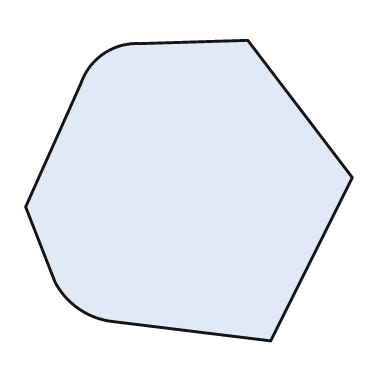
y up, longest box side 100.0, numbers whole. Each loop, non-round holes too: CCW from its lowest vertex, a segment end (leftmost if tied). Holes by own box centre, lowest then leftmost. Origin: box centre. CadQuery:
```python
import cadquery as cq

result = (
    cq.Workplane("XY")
    .moveTo(25.0, -46.0)
    .lineTo(50.0, 4.0)
    .lineTo(18.0, 46.0)
    .lineTo(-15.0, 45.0)
    .threePointArc((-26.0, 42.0), (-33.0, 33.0))
    .lineTo(-50.0, -5.0)
    .lineTo(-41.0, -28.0)
    .threePointArc((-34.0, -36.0), (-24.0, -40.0))
    .close()
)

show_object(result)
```